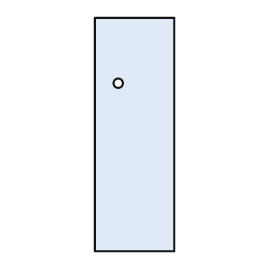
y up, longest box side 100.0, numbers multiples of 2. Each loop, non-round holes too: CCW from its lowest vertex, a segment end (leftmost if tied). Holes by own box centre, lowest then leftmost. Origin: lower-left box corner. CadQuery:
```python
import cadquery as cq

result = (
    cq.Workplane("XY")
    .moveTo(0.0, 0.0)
    .lineTo(34.0, 0.0)
    .lineTo(34.0, 100.0)
    .lineTo(0.0, 100.0)
    .close()
    .moveTo(10.0, 72.0)
    .circle(2.0)
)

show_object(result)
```